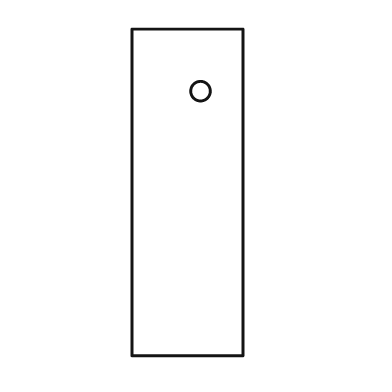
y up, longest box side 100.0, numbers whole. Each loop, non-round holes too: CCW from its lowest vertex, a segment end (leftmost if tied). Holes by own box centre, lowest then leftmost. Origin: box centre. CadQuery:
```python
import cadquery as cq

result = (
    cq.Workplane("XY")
    .moveTo(-17.0, -50.0)
    .lineTo(17.0, -50.0)
    .lineTo(17.0, 50.0)
    .lineTo(-17.0, 50.0)
    .close()
    .moveTo(4.0, 31.0)
    .circle(3.0)
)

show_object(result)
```